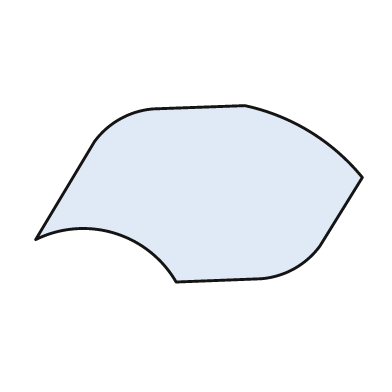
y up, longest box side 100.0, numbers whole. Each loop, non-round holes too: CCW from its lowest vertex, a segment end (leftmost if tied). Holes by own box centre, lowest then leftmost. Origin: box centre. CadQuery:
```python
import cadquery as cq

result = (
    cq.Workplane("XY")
    .moveTo(-7.0, -27.0)
    .lineTo(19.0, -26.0)
    .threePointArc((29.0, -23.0), (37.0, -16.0))
    .lineTo(50.0, 5.0)
    .threePointArc((34.0, 19.0), (14.0, 27.0))
    .lineTo(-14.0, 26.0)
    .threePointArc((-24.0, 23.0), (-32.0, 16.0))
    .lineTo(-50.0, -14.0)
    .threePointArc((-26.0, -12.0), (-7.0, -27.0))
    .close()
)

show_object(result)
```